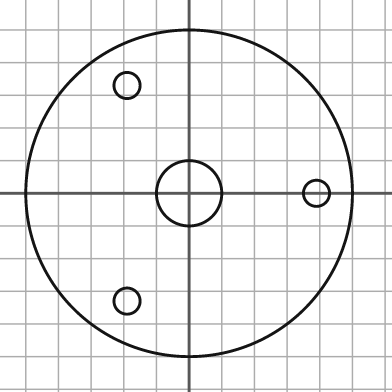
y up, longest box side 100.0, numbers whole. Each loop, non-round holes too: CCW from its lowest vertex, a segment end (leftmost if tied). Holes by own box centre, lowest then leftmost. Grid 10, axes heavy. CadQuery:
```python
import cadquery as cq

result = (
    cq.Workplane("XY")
    .moveTo(0.0, 0.0)
    .circle(50.0)
    .moveTo(-19.0, -33.0)
    .circle(4.0)
    .moveTo(0.0, 0.0)
    .circle(10.0)
    .moveTo(39.0, 0.0)
    .circle(4.0)
    .moveTo(-19.0, 33.0)
    .circle(4.0)
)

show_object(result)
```